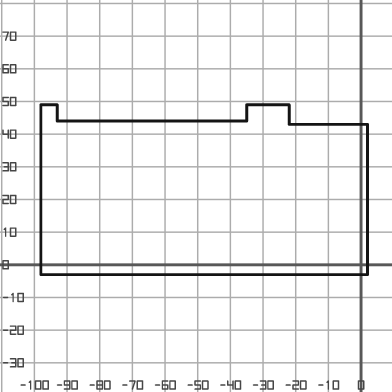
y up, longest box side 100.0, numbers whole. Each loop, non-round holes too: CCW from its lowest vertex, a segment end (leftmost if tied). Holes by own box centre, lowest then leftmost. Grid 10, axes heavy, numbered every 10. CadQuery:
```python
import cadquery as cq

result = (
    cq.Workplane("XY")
    .moveTo(-98.0, -3.0)
    .lineTo(2.0, -3.0)
    .lineTo(2.0, 43.0)
    .lineTo(-22.0, 43.0)
    .lineTo(-22.0, 49.0)
    .lineTo(-35.0, 49.0)
    .lineTo(-35.0, 44.0)
    .lineTo(-93.0, 44.0)
    .lineTo(-93.0, 49.0)
    .lineTo(-98.0, 49.0)
    .close()
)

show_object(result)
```